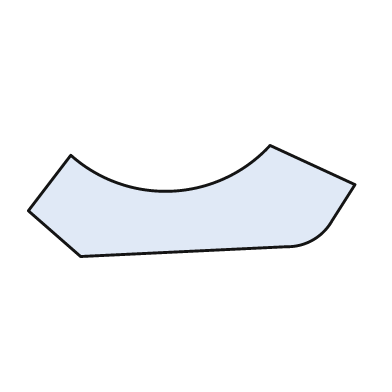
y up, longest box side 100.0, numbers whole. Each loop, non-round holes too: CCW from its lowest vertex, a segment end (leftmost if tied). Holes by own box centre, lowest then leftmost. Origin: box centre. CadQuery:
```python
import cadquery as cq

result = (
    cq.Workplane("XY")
    .moveTo(-34.0, -17.0)
    .lineTo(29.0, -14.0)
    .threePointArc((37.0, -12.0), (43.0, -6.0))
    .lineTo(50.0, 5.0)
    .lineTo(24.0, 17.0)
    .threePointArc((-6.0, 3.0), (-37.0, 14.0))
    .lineTo(-50.0, -3.0)
    .close()
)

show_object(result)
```